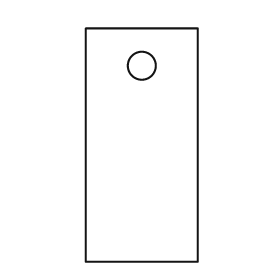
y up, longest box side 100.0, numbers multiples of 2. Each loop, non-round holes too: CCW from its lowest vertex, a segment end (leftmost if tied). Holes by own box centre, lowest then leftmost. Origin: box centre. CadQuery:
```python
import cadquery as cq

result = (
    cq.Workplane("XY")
    .moveTo(-24.0, -50.0)
    .lineTo(24.0, -50.0)
    .lineTo(24.0, 50.0)
    .lineTo(-24.0, 50.0)
    .close()
    .moveTo(0.0, 34.0)
    .circle(6.0)
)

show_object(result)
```